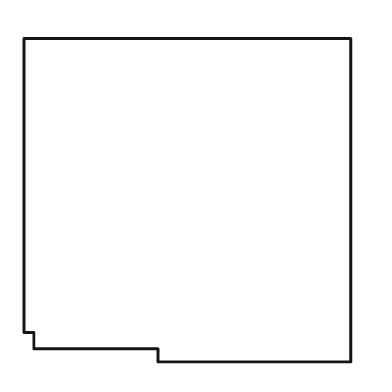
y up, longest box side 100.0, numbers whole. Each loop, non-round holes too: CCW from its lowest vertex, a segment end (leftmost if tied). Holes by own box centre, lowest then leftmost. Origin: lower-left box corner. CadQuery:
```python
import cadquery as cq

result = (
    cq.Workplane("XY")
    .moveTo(41.0, 0.0)
    .lineTo(100.0, 0.0)
    .lineTo(100.0, 99.0)
    .lineTo(0.0, 99.0)
    .lineTo(0.0, 9.0)
    .lineTo(3.0, 9.0)
    .lineTo(3.0, 4.0)
    .lineTo(41.0, 4.0)
    .close()
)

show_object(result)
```